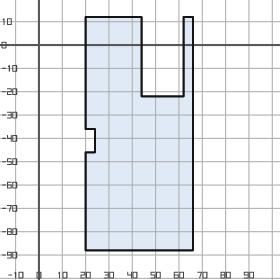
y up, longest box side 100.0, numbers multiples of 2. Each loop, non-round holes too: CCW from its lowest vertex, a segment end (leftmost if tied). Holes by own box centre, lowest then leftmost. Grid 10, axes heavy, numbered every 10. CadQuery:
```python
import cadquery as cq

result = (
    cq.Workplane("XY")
    .moveTo(20.0, -88.0)
    .lineTo(66.0, -88.0)
    .lineTo(66.0, 12.0)
    .lineTo(62.0, 12.0)
    .lineTo(62.0, -22.0)
    .lineTo(44.0, -22.0)
    .lineTo(44.0, 12.0)
    .lineTo(20.0, 12.0)
    .lineTo(20.0, -36.0)
    .lineTo(24.0, -36.0)
    .lineTo(24.0, -46.0)
    .lineTo(20.0, -46.0)
    .close()
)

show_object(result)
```